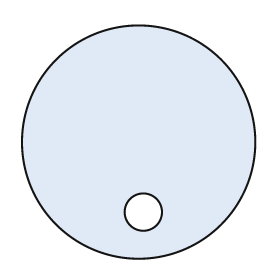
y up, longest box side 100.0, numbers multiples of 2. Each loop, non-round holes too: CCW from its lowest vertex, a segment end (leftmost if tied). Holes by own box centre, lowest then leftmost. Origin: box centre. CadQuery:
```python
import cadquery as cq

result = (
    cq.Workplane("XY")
    .moveTo(0.0, 0.0)
    .circle(50.0)
    .moveTo(2.0, -30.0)
    .circle(8.0)
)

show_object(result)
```